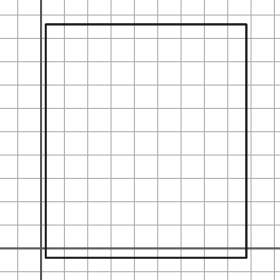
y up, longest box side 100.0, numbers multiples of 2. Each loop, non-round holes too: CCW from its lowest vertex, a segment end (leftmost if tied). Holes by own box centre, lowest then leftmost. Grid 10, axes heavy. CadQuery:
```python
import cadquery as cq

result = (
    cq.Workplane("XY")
    .moveTo(2.0, -4.0)
    .lineTo(88.0, -4.0)
    .lineTo(88.0, 96.0)
    .lineTo(2.0, 96.0)
    .close()
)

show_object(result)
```